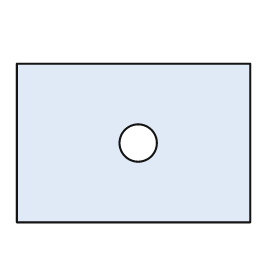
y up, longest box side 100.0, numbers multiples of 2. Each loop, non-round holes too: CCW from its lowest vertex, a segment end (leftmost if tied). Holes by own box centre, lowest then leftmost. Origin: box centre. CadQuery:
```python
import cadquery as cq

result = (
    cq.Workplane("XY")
    .moveTo(-50.0, -34.0)
    .lineTo(50.0, -34.0)
    .lineTo(50.0, 34.0)
    .lineTo(-50.0, 34.0)
    .close()
    .moveTo(2.0, 0.0)
    .circle(8.0)
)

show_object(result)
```